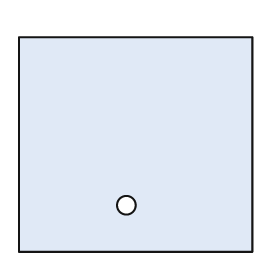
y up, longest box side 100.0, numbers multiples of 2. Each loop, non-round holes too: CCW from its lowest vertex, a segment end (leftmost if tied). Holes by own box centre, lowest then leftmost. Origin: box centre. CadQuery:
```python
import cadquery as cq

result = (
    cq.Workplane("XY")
    .moveTo(-50.0, -46.0)
    .lineTo(50.0, -46.0)
    .lineTo(50.0, 46.0)
    .lineTo(-50.0, 46.0)
    .close()
    .moveTo(-4.0, -26.0)
    .circle(4.0)
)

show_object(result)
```